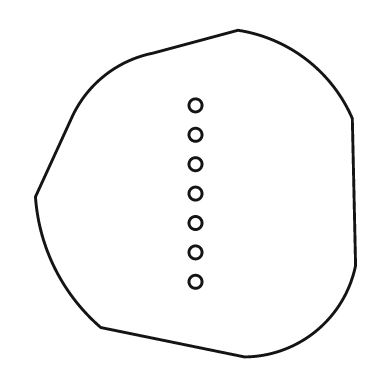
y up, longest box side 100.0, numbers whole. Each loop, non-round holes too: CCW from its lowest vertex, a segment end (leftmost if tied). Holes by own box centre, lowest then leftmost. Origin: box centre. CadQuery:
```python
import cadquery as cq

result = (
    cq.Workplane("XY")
    .moveTo(15.0, -50.0)
    .threePointArc((37.0, -42.0), (49.0, -22.0))
    .lineTo(48.0, 23.0)
    .threePointArc((34.0, 41.0), (13.0, 50.0))
    .lineTo(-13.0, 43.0)
    .threePointArc((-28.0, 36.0), (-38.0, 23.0))
    .lineTo(-49.0, -1.0)
    .threePointArc((-43.0, -23.0), (-29.0, -41.0))
    .close()
    .moveTo(0.0, -27.0)
    .circle(2.0)
    .moveTo(0.0, -18.0)
    .circle(2.0)
    .moveTo(0.0, -9.0)
    .circle(2.0)
    .moveTo(0.0, 0.0)
    .circle(2.0)
    .moveTo(0.0, 9.0)
    .circle(2.0)
    .moveTo(0.0, 18.0)
    .circle(2.0)
    .moveTo(0.0, 27.0)
    .circle(2.0)
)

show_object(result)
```